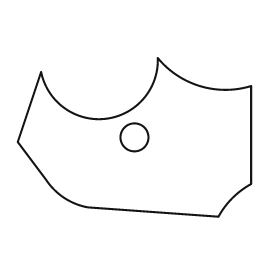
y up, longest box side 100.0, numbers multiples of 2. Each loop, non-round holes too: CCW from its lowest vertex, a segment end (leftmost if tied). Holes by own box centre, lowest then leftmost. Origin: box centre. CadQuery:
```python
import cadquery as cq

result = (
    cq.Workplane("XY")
    .moveTo(36.0, -34.0)
    .threePointArc((42.0, -26.0), (50.0, -20.0))
    .lineTo(50.0, 22.0)
    .threePointArc((28.0, 22.0), (10.0, 34.0))
    .threePointArc((-12.0, 8.0), (-40.0, 28.0))
    .lineTo(-50.0, -2.0)
    .lineTo(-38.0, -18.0)
    .threePointArc((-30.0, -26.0), (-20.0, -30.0))
    .close()
    .moveTo(0.0, 0.0)
    .circle(6.0)
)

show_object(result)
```